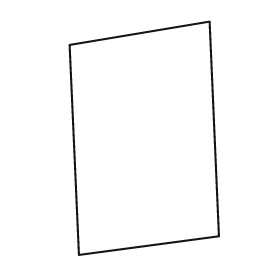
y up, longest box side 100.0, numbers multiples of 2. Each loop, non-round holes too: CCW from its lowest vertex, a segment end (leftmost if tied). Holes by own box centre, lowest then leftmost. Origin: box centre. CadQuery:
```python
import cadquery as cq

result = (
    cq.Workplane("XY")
    .moveTo(-28.0, -50.0)
    .lineTo(32.0, -42.0)
    .lineTo(28.0, 50.0)
    .lineTo(-32.0, 40.0)
    .close()
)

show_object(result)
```